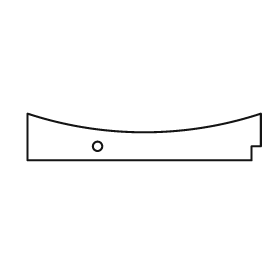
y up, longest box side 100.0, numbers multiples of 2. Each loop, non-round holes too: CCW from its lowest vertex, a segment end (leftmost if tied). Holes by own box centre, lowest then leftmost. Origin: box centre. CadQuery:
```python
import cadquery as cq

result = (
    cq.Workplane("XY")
    .moveTo(-50.0, -10.0)
    .lineTo(46.0, -10.0)
    .lineTo(46.0, -4.0)
    .lineTo(50.0, -4.0)
    .lineTo(50.0, 10.0)
    .threePointArc((0.0, 2.0), (-50.0, 10.0))
    .close()
    .moveTo(-20.0, -4.0)
    .circle(2.0)
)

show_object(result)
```